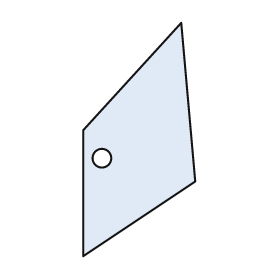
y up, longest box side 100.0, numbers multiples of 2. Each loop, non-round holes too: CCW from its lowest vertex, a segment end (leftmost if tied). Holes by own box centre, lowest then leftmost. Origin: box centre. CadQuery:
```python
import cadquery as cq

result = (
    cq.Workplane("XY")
    .moveTo(-24.0, -50.0)
    .lineTo(24.0, -18.0)
    .lineTo(18.0, 50.0)
    .lineTo(-24.0, 4.0)
    .close()
    .moveTo(-16.0, -8.0)
    .circle(4.0)
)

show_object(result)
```